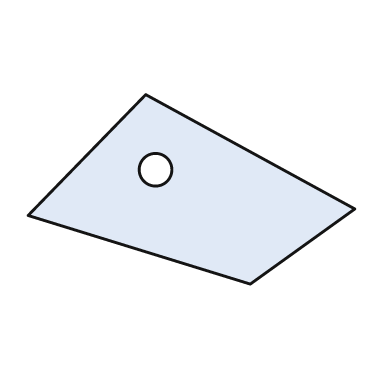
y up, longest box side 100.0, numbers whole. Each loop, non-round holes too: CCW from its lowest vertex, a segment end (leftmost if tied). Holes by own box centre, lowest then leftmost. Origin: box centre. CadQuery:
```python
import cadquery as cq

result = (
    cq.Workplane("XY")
    .moveTo(18.0, -29.0)
    .lineTo(50.0, -6.0)
    .lineTo(-14.0, 29.0)
    .lineTo(-50.0, -8.0)
    .close()
    .moveTo(-11.0, 6.0)
    .circle(5.0)
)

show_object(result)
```